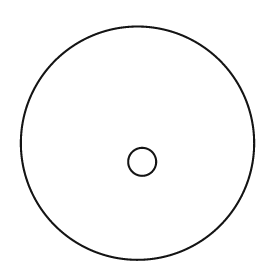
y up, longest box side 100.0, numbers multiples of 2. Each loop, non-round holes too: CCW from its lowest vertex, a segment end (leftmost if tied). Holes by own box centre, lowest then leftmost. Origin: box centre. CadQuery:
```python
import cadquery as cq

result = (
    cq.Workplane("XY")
    .moveTo(0.0, 0.0)
    .circle(50.0)
    .moveTo(2.0, -8.0)
    .circle(6.0)
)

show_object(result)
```